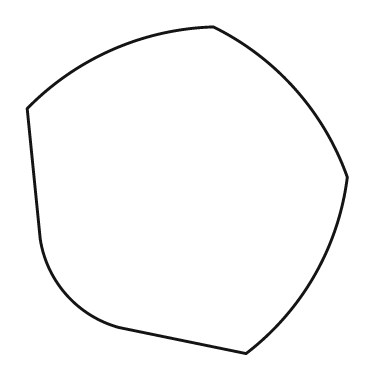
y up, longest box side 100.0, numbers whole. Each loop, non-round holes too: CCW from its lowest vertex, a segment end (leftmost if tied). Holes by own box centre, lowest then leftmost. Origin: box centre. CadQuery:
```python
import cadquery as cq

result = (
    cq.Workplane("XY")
    .moveTo(18.0, -50.0)
    .threePointArc((39.0, -26.0), (49.0, 4.0))
    .threePointArc((33.0, 31.0), (8.0, 50.0))
    .threePointArc((-23.0, 43.0), (-49.0, 25.0))
    .lineTo(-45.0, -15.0)
    .threePointArc((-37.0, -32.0), (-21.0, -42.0))
    .close()
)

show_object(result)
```